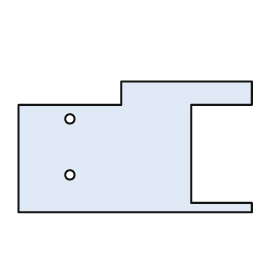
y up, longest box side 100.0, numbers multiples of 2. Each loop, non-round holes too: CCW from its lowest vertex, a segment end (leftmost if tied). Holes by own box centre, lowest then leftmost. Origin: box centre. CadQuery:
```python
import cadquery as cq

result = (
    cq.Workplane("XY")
    .moveTo(-50.0, -28.0)
    .lineTo(50.0, -28.0)
    .lineTo(50.0, -24.0)
    .lineTo(24.0, -24.0)
    .lineTo(24.0, 18.0)
    .lineTo(50.0, 18.0)
    .lineTo(50.0, 28.0)
    .lineTo(-6.0, 28.0)
    .lineTo(-6.0, 18.0)
    .lineTo(-50.0, 18.0)
    .close()
    .moveTo(-28.0, -12.0)
    .circle(2.0)
    .moveTo(-28.0, 12.0)
    .circle(2.0)
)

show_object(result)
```